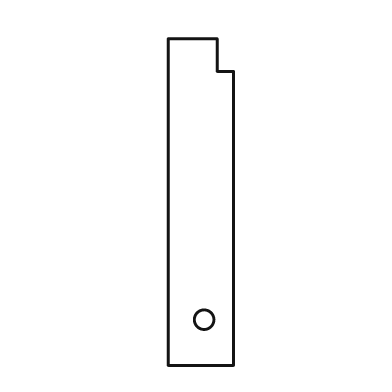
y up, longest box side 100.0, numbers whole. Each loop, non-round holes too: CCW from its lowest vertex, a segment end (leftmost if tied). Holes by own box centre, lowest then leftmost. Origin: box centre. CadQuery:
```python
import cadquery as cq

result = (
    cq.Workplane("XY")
    .moveTo(-10.0, -50.0)
    .lineTo(10.0, -50.0)
    .lineTo(10.0, 40.0)
    .lineTo(5.0, 40.0)
    .lineTo(5.0, 50.0)
    .lineTo(-10.0, 50.0)
    .close()
    .moveTo(1.0, -36.0)
    .circle(3.0)
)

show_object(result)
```